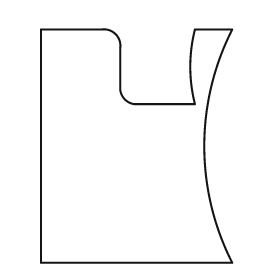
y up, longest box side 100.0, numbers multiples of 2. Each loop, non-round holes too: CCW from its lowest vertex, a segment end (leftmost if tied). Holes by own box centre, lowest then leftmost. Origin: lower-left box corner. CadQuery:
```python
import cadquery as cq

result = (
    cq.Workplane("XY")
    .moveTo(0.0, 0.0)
    .lineTo(82.0, 0.0)
    .threePointArc((70.0, 50.0), (82.0, 100.0))
    .lineTo(66.0, 100.0)
    .threePointArc((64.0, 84.0), (66.0, 68.0))
    .lineTo(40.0, 68.0)
    .threePointArc((36.0, 70.0), (34.0, 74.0))
    .lineTo(34.0, 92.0)
    .threePointArc((32.0, 98.0), (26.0, 100.0))
    .lineTo(0.0, 100.0)
    .close()
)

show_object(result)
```